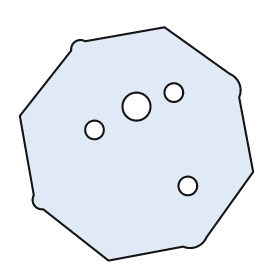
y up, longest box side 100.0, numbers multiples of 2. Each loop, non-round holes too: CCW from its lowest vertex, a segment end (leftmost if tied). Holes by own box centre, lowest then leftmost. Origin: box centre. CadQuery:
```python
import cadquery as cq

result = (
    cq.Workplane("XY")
    .moveTo(-12.0, -50.0)
    .lineTo(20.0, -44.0)
    .threePointArc((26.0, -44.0), (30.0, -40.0))
    .lineTo(50.0, -12.0)
    .lineTo(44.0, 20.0)
    .threePointArc((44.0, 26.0), (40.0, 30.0))
    .lineTo(12.0, 50.0)
    .lineTo(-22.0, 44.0)
    .threePointArc((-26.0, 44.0), (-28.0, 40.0))
    .lineTo(-50.0, 12.0)
    .lineTo(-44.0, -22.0)
    .threePointArc((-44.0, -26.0), (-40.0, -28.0))
    .close()
    .moveTo(22.0, -18.0)
    .circle(4.0)
    .moveTo(-18.0, 6.0)
    .circle(4.0)
    .moveTo(0.0, 16.0)
    .circle(6.0)
    .moveTo(16.0, 22.0)
    .circle(4.0)
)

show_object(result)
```